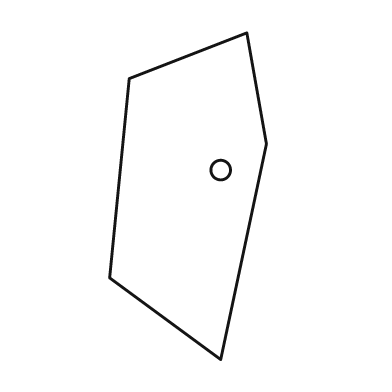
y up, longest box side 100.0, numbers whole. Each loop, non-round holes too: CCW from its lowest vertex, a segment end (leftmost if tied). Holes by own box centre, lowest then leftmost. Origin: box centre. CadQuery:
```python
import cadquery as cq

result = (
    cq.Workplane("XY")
    .moveTo(10.0, -50.0)
    .lineTo(24.0, 16.0)
    .lineTo(18.0, 50.0)
    .lineTo(-18.0, 36.0)
    .lineTo(-24.0, -25.0)
    .close()
    .moveTo(10.0, 8.0)
    .circle(3.0)
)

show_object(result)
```